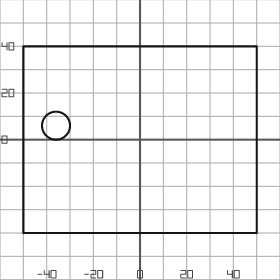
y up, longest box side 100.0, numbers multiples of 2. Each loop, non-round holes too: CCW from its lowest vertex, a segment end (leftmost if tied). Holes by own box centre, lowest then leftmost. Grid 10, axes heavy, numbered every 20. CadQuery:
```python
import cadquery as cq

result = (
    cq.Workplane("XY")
    .moveTo(-50.0, -40.0)
    .lineTo(50.0, -40.0)
    .lineTo(50.0, 40.0)
    .lineTo(-50.0, 40.0)
    .close()
    .moveTo(-36.0, 6.0)
    .circle(6.0)
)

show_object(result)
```